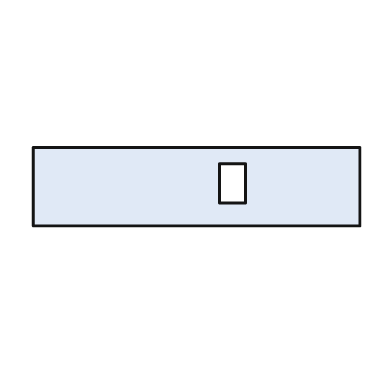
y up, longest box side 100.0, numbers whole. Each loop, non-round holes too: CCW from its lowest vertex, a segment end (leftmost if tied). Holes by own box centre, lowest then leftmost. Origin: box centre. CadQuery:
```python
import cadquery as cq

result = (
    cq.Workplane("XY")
    .moveTo(-50.0, -12.0)
    .lineTo(50.0, -12.0)
    .lineTo(50.0, 12.0)
    .lineTo(-50.0, 12.0)
    .close()
    .moveTo(7.0, -5.0)
    .lineTo(15.0, -5.0)
    .lineTo(15.0, 7.0)
    .lineTo(7.0, 7.0)
    .close()
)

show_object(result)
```